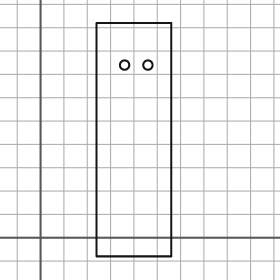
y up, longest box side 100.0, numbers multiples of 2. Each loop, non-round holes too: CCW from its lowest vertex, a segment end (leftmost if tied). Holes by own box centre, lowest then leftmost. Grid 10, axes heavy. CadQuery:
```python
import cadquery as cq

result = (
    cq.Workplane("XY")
    .moveTo(24.0, -8.0)
    .lineTo(56.0, -8.0)
    .lineTo(56.0, 92.0)
    .lineTo(24.0, 92.0)
    .close()
    .moveTo(36.0, 74.0)
    .circle(2.0)
    .moveTo(46.0, 74.0)
    .circle(2.0)
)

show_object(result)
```